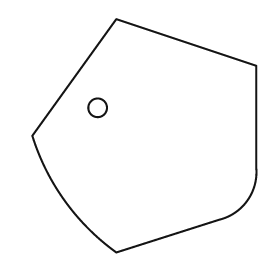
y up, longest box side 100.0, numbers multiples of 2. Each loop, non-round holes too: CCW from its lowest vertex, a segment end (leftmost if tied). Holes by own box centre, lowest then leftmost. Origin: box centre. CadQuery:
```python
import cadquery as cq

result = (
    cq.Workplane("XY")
    .moveTo(-12.0, -50.0)
    .lineTo(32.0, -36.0)
    .threePointArc((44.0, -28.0), (48.0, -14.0))
    .lineTo(48.0, 30.0)
    .lineTo(-12.0, 50.0)
    .lineTo(-48.0, 0.0)
    .threePointArc((-34.0, -28.0), (-12.0, -50.0))
    .close()
    .moveTo(-20.0, 12.0)
    .circle(4.0)
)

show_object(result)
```